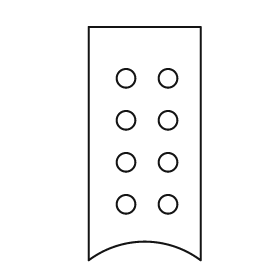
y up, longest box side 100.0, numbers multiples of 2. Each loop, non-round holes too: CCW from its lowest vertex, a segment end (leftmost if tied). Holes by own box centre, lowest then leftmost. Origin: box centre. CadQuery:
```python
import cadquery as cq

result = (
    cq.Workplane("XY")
    .moveTo(-24.0, -50.0)
    .threePointArc((0.0, -42.0), (24.0, -50.0))
    .lineTo(24.0, 50.0)
    .lineTo(-24.0, 50.0)
    .close()
    .moveTo(-8.0, -26.0)
    .circle(4.0)
    .moveTo(10.0, -26.0)
    .circle(4.0)
    .moveTo(-8.0, -8.0)
    .circle(4.0)
    .moveTo(10.0, -8.0)
    .circle(4.0)
    .moveTo(-8.0, 10.0)
    .circle(4.0)
    .moveTo(10.0, 10.0)
    .circle(4.0)
    .moveTo(-8.0, 28.0)
    .circle(4.0)
    .moveTo(10.0, 28.0)
    .circle(4.0)
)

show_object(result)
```